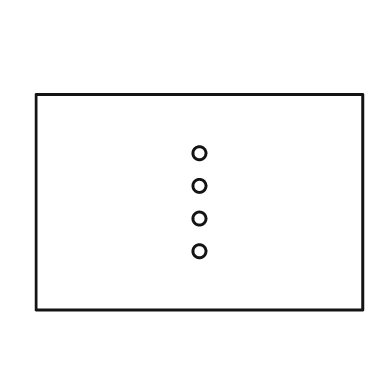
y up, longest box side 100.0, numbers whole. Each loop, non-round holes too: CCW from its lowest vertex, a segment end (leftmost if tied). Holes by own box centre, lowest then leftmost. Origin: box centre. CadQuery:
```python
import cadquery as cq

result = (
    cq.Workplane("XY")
    .moveTo(-50.0, -33.0)
    .lineTo(50.0, -33.0)
    .lineTo(50.0, 33.0)
    .lineTo(-50.0, 33.0)
    .close()
    .moveTo(0.0, -15.0)
    .circle(2.0)
    .moveTo(0.0, -5.0)
    .circle(2.0)
    .moveTo(0.0, 5.0)
    .circle(2.0)
    .moveTo(0.0, 15.0)
    .circle(2.0)
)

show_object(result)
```